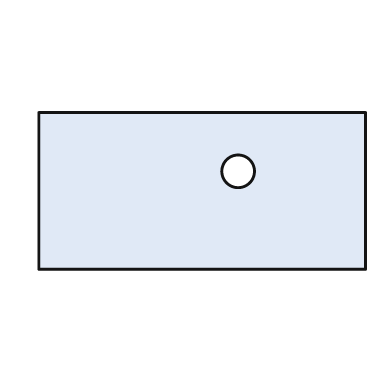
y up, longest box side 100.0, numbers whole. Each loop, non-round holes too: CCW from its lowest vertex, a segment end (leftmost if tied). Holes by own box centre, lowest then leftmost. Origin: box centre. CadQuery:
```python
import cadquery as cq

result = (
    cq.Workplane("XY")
    .moveTo(-50.0, -24.0)
    .lineTo(50.0, -24.0)
    .lineTo(50.0, 24.0)
    .lineTo(-50.0, 24.0)
    .close()
    .moveTo(11.0, 6.0)
    .circle(5.0)
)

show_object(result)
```